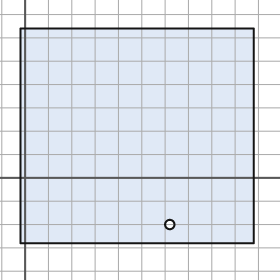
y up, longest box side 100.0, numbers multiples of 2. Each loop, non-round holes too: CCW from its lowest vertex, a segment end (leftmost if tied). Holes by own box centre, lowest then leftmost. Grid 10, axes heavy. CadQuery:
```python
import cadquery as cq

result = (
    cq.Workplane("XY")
    .moveTo(-2.0, -28.0)
    .lineTo(98.0, -28.0)
    .lineTo(98.0, 64.0)
    .lineTo(-2.0, 64.0)
    .close()
    .moveTo(62.0, -20.0)
    .circle(2.0)
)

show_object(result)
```